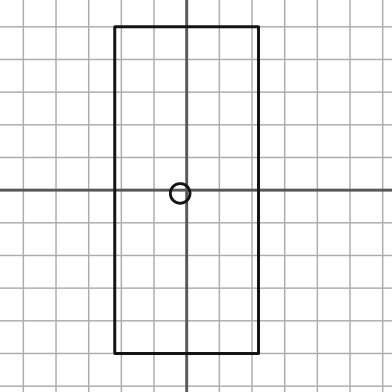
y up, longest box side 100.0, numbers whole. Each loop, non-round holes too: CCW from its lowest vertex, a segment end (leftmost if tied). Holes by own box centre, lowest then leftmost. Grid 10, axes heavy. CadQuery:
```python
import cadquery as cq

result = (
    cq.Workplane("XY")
    .moveTo(-22.0, -50.0)
    .lineTo(22.0, -50.0)
    .lineTo(22.0, 50.0)
    .lineTo(-22.0, 50.0)
    .close()
    .moveTo(-2.0, -1.0)
    .circle(3.0)
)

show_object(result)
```